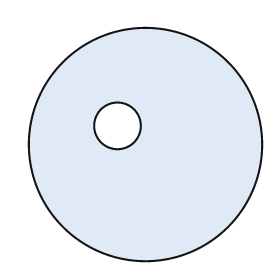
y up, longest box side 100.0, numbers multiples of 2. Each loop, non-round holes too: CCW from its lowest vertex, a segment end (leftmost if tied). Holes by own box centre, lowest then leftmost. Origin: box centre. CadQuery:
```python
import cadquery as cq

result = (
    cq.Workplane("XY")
    .moveTo(0.0, 0.0)
    .circle(50.0)
    .moveTo(-12.0, 8.0)
    .circle(10.0)
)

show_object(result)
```